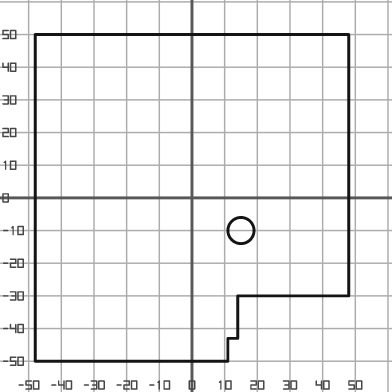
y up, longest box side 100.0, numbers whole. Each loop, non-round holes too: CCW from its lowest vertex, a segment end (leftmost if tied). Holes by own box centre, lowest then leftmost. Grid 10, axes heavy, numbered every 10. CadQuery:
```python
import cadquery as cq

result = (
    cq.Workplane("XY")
    .moveTo(-48.0, -50.0)
    .lineTo(11.0, -50.0)
    .lineTo(11.0, -43.0)
    .lineTo(14.0, -43.0)
    .lineTo(14.0, -30.0)
    .lineTo(48.0, -30.0)
    .lineTo(48.0, 50.0)
    .lineTo(-48.0, 50.0)
    .close()
    .moveTo(15.0, -10.0)
    .circle(4.0)
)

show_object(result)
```